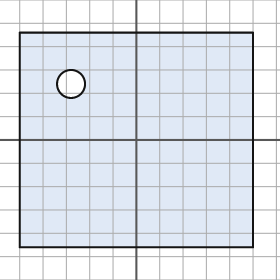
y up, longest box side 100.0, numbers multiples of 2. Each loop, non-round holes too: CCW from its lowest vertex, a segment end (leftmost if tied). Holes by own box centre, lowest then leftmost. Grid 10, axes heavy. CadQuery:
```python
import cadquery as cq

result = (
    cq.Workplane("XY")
    .moveTo(-50.0, -46.0)
    .lineTo(50.0, -46.0)
    .lineTo(50.0, 46.0)
    .lineTo(-50.0, 46.0)
    .close()
    .moveTo(-28.0, 24.0)
    .circle(6.0)
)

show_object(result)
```